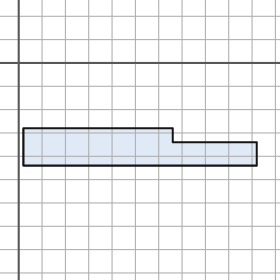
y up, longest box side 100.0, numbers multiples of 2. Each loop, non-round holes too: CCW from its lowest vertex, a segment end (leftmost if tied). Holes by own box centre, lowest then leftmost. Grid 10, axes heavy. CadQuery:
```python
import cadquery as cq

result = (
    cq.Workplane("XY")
    .moveTo(2.0, -44.0)
    .lineTo(102.0, -44.0)
    .lineTo(102.0, -34.0)
    .lineTo(66.0, -34.0)
    .lineTo(66.0, -28.0)
    .lineTo(2.0, -28.0)
    .close()
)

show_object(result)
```